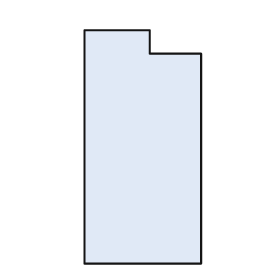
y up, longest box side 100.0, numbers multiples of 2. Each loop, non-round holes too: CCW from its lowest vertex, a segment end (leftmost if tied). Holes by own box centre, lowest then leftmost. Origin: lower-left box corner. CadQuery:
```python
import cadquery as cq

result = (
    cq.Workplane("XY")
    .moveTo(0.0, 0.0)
    .lineTo(50.0, 0.0)
    .lineTo(50.0, 90.0)
    .lineTo(28.0, 90.0)
    .lineTo(28.0, 100.0)
    .lineTo(0.0, 100.0)
    .close()
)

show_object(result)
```